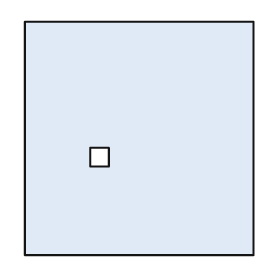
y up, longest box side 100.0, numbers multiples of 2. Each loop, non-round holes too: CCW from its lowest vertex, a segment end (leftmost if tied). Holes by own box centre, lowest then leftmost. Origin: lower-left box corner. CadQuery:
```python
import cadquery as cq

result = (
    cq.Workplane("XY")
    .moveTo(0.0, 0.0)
    .lineTo(98.0, 0.0)
    .lineTo(98.0, 100.0)
    .lineTo(0.0, 100.0)
    .close()
    .moveTo(28.0, 38.0)
    .lineTo(36.0, 38.0)
    .lineTo(36.0, 46.0)
    .lineTo(28.0, 46.0)
    .close()
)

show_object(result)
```